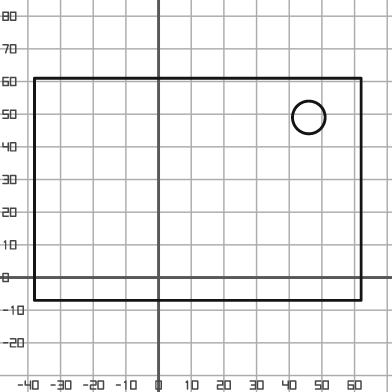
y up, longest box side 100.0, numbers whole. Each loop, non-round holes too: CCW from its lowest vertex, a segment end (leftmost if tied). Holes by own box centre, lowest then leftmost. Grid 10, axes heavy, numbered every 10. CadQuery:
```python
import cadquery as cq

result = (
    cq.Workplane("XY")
    .moveTo(-38.0, -7.0)
    .lineTo(62.0, -7.0)
    .lineTo(62.0, 61.0)
    .lineTo(-38.0, 61.0)
    .close()
    .moveTo(46.0, 49.0)
    .circle(5.0)
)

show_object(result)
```